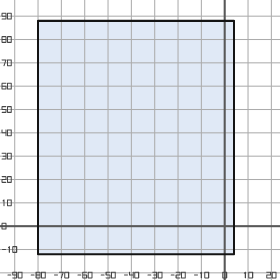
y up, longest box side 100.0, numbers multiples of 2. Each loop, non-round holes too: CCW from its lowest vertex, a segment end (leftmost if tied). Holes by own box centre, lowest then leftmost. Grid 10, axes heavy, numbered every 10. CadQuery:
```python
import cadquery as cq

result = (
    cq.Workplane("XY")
    .moveTo(-80.0, -12.0)
    .lineTo(4.0, -12.0)
    .lineTo(4.0, 88.0)
    .lineTo(-80.0, 88.0)
    .close()
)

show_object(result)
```